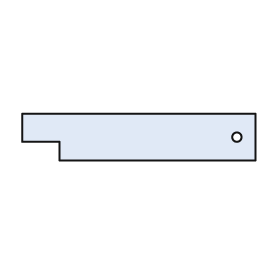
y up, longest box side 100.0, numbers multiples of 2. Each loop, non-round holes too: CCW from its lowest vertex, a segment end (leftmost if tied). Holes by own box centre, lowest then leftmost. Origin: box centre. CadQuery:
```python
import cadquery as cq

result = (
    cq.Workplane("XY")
    .moveTo(-34.0, -10.0)
    .lineTo(50.0, -10.0)
    .lineTo(50.0, 10.0)
    .lineTo(-50.0, 10.0)
    .lineTo(-50.0, -2.0)
    .lineTo(-34.0, -2.0)
    .close()
    .moveTo(42.0, 0.0)
    .circle(2.0)
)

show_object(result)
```